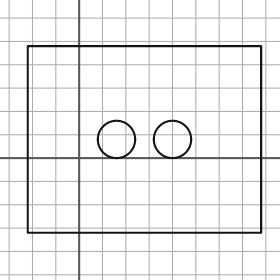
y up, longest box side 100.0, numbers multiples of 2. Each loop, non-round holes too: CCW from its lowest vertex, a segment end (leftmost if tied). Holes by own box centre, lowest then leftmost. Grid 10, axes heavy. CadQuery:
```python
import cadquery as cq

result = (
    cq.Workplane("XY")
    .moveTo(-22.0, -32.0)
    .lineTo(78.0, -32.0)
    .lineTo(78.0, 48.0)
    .lineTo(-22.0, 48.0)
    .close()
    .moveTo(16.0, 8.0)
    .circle(8.0)
    .moveTo(40.0, 8.0)
    .circle(8.0)
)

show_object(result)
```